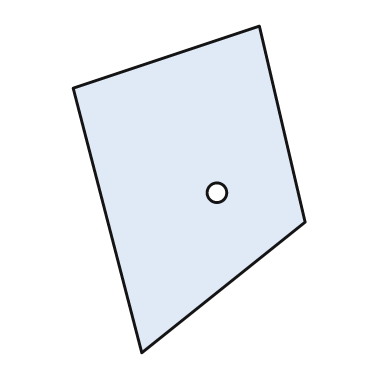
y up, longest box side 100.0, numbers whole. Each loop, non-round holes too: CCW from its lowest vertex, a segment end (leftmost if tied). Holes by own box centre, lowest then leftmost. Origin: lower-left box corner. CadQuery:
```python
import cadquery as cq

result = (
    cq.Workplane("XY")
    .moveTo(21.0, 0.0)
    .lineTo(71.0, 40.0)
    .lineTo(57.0, 100.0)
    .lineTo(0.0, 81.0)
    .close()
    .moveTo(44.0, 49.0)
    .circle(3.0)
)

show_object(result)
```